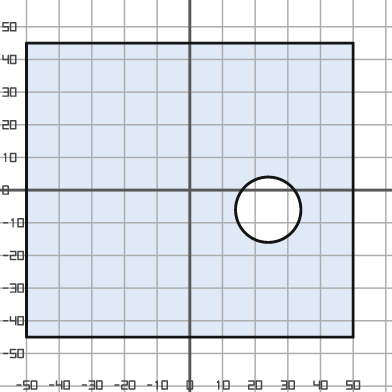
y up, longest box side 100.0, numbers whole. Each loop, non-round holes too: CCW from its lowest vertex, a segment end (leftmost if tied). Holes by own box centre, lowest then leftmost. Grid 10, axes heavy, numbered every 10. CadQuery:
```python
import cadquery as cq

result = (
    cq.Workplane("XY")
    .moveTo(-50.0, -45.0)
    .lineTo(50.0, -45.0)
    .lineTo(50.0, 45.0)
    .lineTo(-50.0, 45.0)
    .close()
    .moveTo(24.0, -6.0)
    .circle(10.0)
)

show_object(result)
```